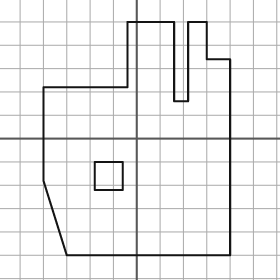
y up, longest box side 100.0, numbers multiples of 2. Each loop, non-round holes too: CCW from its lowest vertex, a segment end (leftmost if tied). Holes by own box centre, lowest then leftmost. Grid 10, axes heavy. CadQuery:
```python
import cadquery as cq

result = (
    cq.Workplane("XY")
    .moveTo(-30.0, -50.0)
    .lineTo(40.0, -50.0)
    .lineTo(40.0, 34.0)
    .lineTo(30.0, 34.0)
    .lineTo(30.0, 50.0)
    .lineTo(22.0, 50.0)
    .lineTo(22.0, 16.0)
    .lineTo(16.0, 16.0)
    .lineTo(16.0, 50.0)
    .lineTo(-4.0, 50.0)
    .lineTo(-4.0, 22.0)
    .lineTo(-40.0, 22.0)
    .lineTo(-40.0, -18.0)
    .close()
    .moveTo(-18.0, -22.0)
    .lineTo(-6.0, -22.0)
    .lineTo(-6.0, -10.0)
    .lineTo(-18.0, -10.0)
    .close()
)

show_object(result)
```